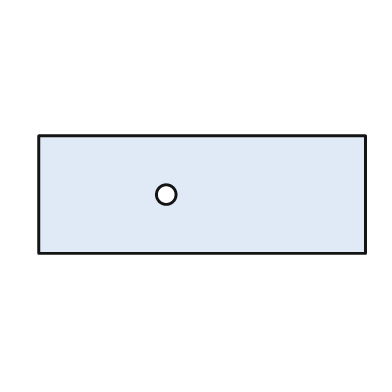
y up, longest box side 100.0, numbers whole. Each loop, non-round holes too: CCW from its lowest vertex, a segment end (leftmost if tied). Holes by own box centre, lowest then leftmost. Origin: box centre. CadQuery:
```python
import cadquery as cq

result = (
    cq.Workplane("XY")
    .moveTo(-50.0, -18.0)
    .lineTo(50.0, -18.0)
    .lineTo(50.0, 18.0)
    .lineTo(-50.0, 18.0)
    .close()
    .moveTo(-11.0, 0.0)
    .circle(3.0)
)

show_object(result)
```